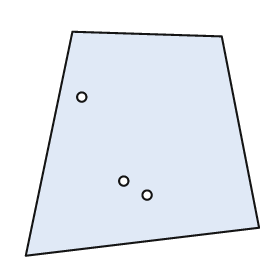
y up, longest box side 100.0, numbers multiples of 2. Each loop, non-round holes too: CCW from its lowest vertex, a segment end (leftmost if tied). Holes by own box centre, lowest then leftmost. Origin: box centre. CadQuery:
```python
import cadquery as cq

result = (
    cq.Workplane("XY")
    .moveTo(-50.0, -48.0)
    .lineTo(50.0, -36.0)
    .lineTo(34.0, 46.0)
    .lineTo(-30.0, 48.0)
    .close()
    .moveTo(2.0, -22.0)
    .circle(2.0)
    .moveTo(-8.0, -16.0)
    .circle(2.0)
    .moveTo(-26.0, 20.0)
    .circle(2.0)
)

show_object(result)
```